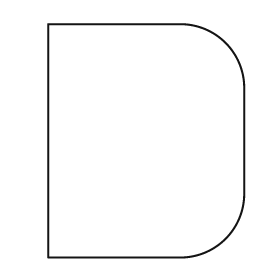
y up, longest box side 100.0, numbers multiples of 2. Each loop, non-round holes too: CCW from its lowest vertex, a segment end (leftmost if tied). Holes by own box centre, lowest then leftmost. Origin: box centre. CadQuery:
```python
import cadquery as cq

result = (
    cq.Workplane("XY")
    .moveTo(-42.0, -50.0)
    .lineTo(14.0, -50.0)
    .threePointArc((34.0, -42.0), (42.0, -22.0))
    .lineTo(42.0, 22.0)
    .threePointArc((34.0, 42.0), (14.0, 50.0))
    .lineTo(-42.0, 50.0)
    .close()
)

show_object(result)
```